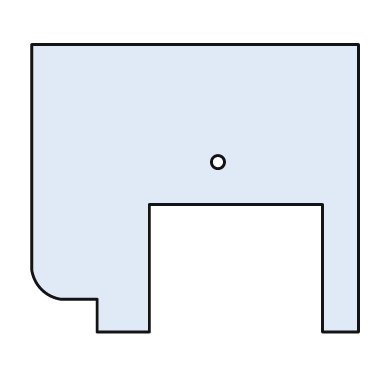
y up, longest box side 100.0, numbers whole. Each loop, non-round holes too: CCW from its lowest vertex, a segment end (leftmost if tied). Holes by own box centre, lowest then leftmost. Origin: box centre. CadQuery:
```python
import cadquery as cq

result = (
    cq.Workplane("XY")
    .moveTo(-30.0, -44.0)
    .lineTo(-14.0, -44.0)
    .lineTo(-14.0, -5.0)
    .lineTo(39.0, -5.0)
    .lineTo(39.0, -44.0)
    .lineTo(50.0, -44.0)
    .lineTo(50.0, 44.0)
    .lineTo(-50.0, 44.0)
    .lineTo(-50.0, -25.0)
    .threePointArc((-47.0, -31.0), (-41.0, -34.0))
    .lineTo(-30.0, -34.0)
    .close()
    .moveTo(7.0, 8.0)
    .circle(2.0)
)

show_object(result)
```